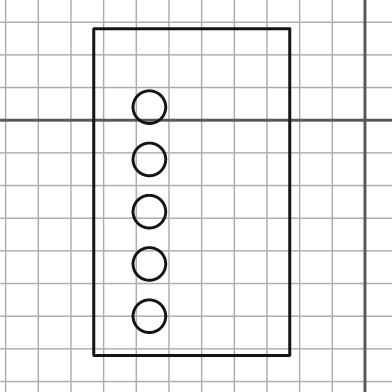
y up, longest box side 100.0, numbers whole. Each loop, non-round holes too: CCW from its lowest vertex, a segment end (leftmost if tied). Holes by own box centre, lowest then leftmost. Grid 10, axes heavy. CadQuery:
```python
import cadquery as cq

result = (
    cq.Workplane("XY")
    .moveTo(-83.0, -72.0)
    .lineTo(-23.0, -72.0)
    .lineTo(-23.0, 28.0)
    .lineTo(-83.0, 28.0)
    .close()
    .moveTo(-66.0, -60.0)
    .circle(5.0)
    .moveTo(-66.0, -44.0)
    .circle(5.0)
    .moveTo(-66.0, -28.0)
    .circle(5.0)
    .moveTo(-66.0, -12.0)
    .circle(5.0)
    .moveTo(-66.0, 4.0)
    .circle(5.0)
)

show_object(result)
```